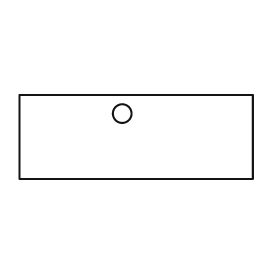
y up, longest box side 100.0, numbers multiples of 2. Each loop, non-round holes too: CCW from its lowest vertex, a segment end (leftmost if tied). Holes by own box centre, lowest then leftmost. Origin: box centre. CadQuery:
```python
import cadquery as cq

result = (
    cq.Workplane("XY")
    .moveTo(-50.0, -18.0)
    .lineTo(50.0, -18.0)
    .lineTo(50.0, 18.0)
    .lineTo(-50.0, 18.0)
    .close()
    .moveTo(-6.0, 10.0)
    .circle(4.0)
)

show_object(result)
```